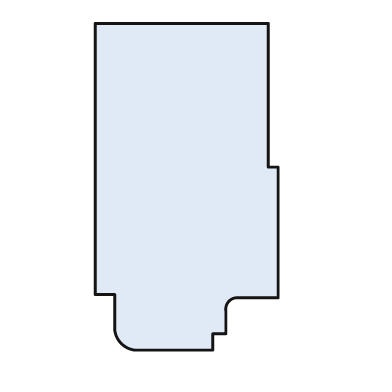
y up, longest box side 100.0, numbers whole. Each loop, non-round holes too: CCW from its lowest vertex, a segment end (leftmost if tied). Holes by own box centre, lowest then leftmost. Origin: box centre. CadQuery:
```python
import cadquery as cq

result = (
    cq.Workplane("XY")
    .moveTo(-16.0, -50.0)
    .lineTo(8.0, -50.0)
    .lineTo(8.0, -45.0)
    .lineTo(12.0, -45.0)
    .lineTo(12.0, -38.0)
    .threePointArc((13.0, -35.0), (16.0, -34.0))
    .lineTo(28.0, -34.0)
    .lineTo(28.0, 6.0)
    .lineTo(25.0, 6.0)
    .lineTo(25.0, 50.0)
    .lineTo(-28.0, 50.0)
    .lineTo(-28.0, -33.0)
    .lineTo(-22.0, -33.0)
    .lineTo(-22.0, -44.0)
    .threePointArc((-20.0, -48.0), (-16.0, -50.0))
    .close()
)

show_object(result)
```